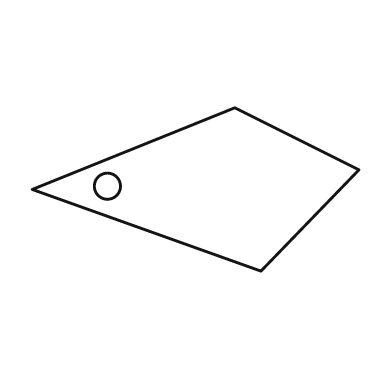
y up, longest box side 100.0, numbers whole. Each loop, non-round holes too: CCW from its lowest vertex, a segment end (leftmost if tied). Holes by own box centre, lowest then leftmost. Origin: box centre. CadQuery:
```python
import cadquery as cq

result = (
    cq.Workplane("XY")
    .moveTo(20.0, -25.0)
    .lineTo(50.0, 6.0)
    .lineTo(12.0, 25.0)
    .lineTo(-50.0, 0.0)
    .close()
    .moveTo(-27.0, 1.0)
    .circle(4.0)
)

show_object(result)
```